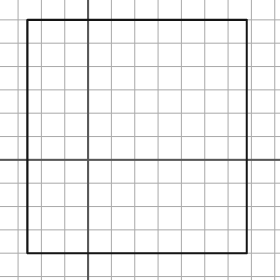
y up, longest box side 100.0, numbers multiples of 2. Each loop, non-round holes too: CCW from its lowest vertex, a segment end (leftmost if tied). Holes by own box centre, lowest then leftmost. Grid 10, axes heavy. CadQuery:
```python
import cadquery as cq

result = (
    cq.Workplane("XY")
    .moveTo(-26.0, -40.0)
    .lineTo(68.0, -40.0)
    .lineTo(68.0, 60.0)
    .lineTo(-26.0, 60.0)
    .close()
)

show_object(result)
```